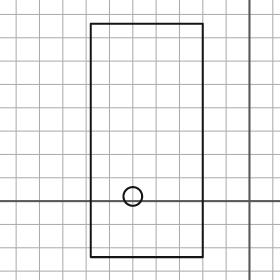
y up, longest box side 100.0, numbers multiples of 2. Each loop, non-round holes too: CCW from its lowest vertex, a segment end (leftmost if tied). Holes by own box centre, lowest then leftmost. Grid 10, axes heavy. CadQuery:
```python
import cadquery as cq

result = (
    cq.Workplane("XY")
    .moveTo(-68.0, -24.0)
    .lineTo(-20.0, -24.0)
    .lineTo(-20.0, 76.0)
    .lineTo(-68.0, 76.0)
    .close()
    .moveTo(-50.0, 2.0)
    .circle(4.0)
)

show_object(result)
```